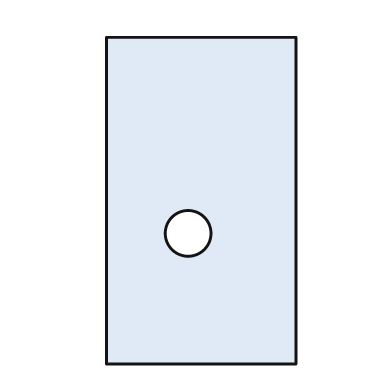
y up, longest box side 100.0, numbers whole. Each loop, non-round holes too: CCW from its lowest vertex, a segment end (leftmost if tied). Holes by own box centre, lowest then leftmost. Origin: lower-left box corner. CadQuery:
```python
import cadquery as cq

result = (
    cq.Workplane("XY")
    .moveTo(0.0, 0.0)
    .lineTo(58.0, 0.0)
    .lineTo(58.0, 100.0)
    .lineTo(0.0, 100.0)
    .close()
    .moveTo(25.0, 40.0)
    .circle(7.0)
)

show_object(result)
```